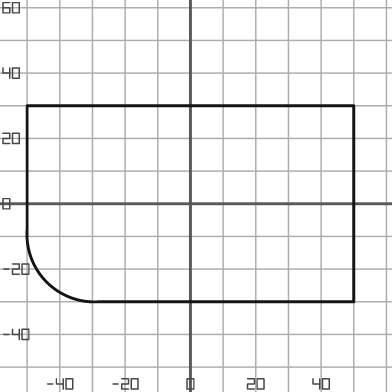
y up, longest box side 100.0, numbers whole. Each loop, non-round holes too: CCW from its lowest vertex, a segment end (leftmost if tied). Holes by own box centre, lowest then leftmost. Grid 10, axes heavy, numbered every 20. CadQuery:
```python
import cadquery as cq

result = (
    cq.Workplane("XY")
    .moveTo(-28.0, -30.0)
    .lineTo(50.0, -30.0)
    .lineTo(50.0, 30.0)
    .lineTo(-50.0, 30.0)
    .lineTo(-50.0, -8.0)
    .threePointArc((-44.0, -24.0), (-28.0, -30.0))
    .close()
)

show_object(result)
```